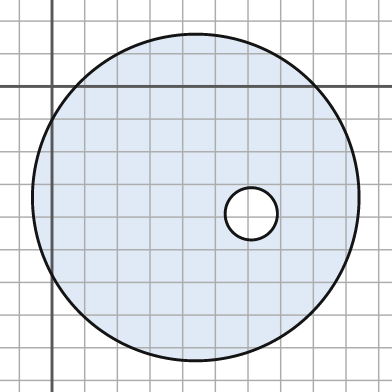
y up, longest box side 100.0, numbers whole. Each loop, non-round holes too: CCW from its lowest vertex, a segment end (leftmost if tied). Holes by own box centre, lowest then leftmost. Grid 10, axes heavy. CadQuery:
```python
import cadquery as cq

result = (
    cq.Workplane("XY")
    .moveTo(44.0, -34.0)
    .circle(50.0)
    .moveTo(61.0, -39.0)
    .circle(8.0)
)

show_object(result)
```